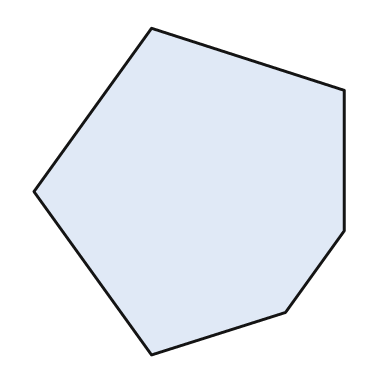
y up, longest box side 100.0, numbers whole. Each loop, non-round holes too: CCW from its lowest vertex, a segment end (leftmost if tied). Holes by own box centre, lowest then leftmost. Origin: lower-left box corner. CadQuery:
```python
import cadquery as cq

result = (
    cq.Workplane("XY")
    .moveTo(36.0, 0.0)
    .lineTo(77.0, 13.0)
    .lineTo(95.0, 38.0)
    .lineTo(95.0, 81.0)
    .lineTo(36.0, 100.0)
    .lineTo(0.0, 50.0)
    .close()
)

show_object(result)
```